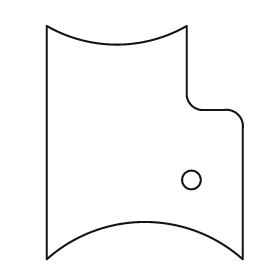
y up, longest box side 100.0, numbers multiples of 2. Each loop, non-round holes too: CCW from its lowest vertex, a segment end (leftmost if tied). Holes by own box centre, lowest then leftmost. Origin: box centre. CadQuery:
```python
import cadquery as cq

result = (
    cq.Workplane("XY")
    .moveTo(-42.0, -50.0)
    .threePointArc((0.0, -34.0), (42.0, -50.0))
    .lineTo(42.0, 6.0)
    .threePointArc((40.0, 12.0), (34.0, 14.0))
    .lineTo(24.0, 14.0)
    .threePointArc((20.0, 16.0), (18.0, 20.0))
    .lineTo(18.0, 50.0)
    .threePointArc((-12.0, 42.0), (-42.0, 50.0))
    .close()
    .moveTo(20.0, -16.0)
    .circle(4.0)
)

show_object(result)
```